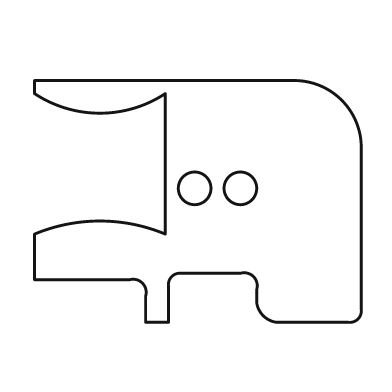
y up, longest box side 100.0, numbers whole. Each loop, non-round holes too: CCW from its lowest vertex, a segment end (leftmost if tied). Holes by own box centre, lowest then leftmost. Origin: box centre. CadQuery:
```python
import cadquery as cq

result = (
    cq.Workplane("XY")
    .moveTo(-16.0, -37.0)
    .lineTo(-9.0, -37.0)
    .lineTo(-9.0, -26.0)
    .threePointArc((-8.0, -23.0), (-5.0, -22.0))
    .lineTo(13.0, -22.0)
    .threePointArc((17.0, -23.0), (18.0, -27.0))
    .lineTo(18.0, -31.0)
    .threePointArc((20.0, -35.0), (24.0, -37.0))
    .lineTo(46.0, -37.0)
    .threePointArc((49.0, -36.0), (50.0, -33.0))
    .lineTo(50.0, 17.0)
    .threePointArc((44.0, 31.0), (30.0, 37.0))
    .lineTo(-50.0, 37.0)
    .lineTo(-50.0, 33.0)
    .threePointArc((-30.0, 27.0), (-10.0, 33.0))
    .lineTo(-10.0, -10.0)
    .threePointArc((-30.0, -6.0), (-50.0, -10.0))
    .lineTo(-50.0, -24.0)
    .lineTo(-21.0, -24.0)
    .threePointArc((-17.0, -25.0), (-16.0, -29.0))
    .close()
    .moveTo(-1.0, 4.0)
    .circle(5.0)
    .moveTo(13.0, 4.0)
    .circle(5.0)
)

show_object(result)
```